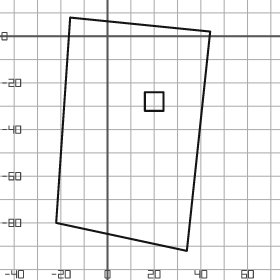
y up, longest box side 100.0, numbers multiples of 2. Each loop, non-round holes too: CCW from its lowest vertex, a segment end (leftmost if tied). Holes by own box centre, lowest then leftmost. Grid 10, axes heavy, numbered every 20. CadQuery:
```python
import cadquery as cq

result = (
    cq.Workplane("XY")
    .moveTo(34.0, -92.0)
    .lineTo(44.0, 2.0)
    .lineTo(-16.0, 8.0)
    .lineTo(-22.0, -80.0)
    .close()
    .moveTo(16.0, -32.0)
    .lineTo(24.0, -32.0)
    .lineTo(24.0, -24.0)
    .lineTo(16.0, -24.0)
    .close()
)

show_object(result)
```